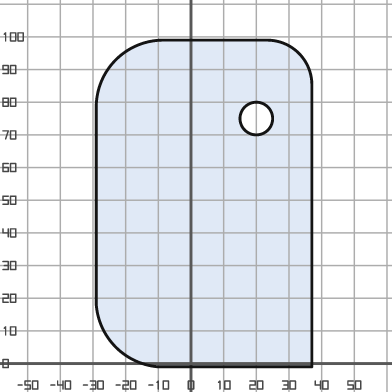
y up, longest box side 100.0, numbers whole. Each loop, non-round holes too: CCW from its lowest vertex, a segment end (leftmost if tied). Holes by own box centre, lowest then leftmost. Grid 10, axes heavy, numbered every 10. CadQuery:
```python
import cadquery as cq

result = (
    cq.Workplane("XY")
    .moveTo(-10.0, -1.0)
    .lineTo(37.0, -1.0)
    .lineTo(37.0, 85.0)
    .threePointArc((33.0, 95.0), (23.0, 99.0))
    .lineTo(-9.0, 99.0)
    .threePointArc((-23.0, 93.0), (-29.0, 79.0))
    .lineTo(-29.0, 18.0)
    .threePointArc((-23.0, 5.0), (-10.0, -1.0))
    .close()
    .moveTo(20.0, 75.0)
    .circle(5.0)
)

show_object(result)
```